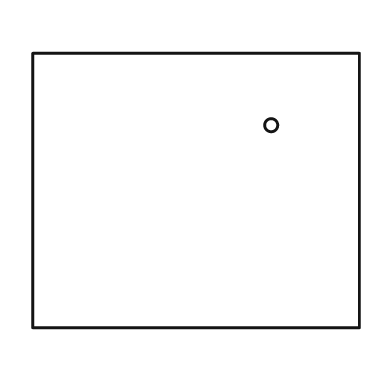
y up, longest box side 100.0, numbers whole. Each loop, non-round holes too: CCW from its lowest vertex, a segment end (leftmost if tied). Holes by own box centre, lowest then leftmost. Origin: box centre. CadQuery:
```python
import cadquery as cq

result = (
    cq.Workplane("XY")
    .moveTo(-50.0, -42.0)
    .lineTo(50.0, -42.0)
    .lineTo(50.0, 42.0)
    .lineTo(-50.0, 42.0)
    .close()
    .moveTo(23.0, 20.0)
    .circle(2.0)
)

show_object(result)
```